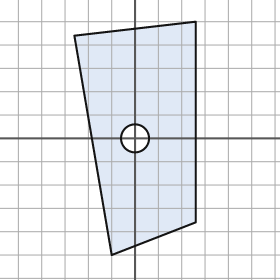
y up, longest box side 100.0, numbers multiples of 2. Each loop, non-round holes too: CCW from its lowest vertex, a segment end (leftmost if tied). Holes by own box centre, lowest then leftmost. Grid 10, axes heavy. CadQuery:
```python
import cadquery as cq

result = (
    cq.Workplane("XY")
    .moveTo(-10.0, -50.0)
    .lineTo(26.0, -36.0)
    .lineTo(26.0, 50.0)
    .lineTo(-26.0, 44.0)
    .close()
    .moveTo(0.0, 0.0)
    .circle(6.0)
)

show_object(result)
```